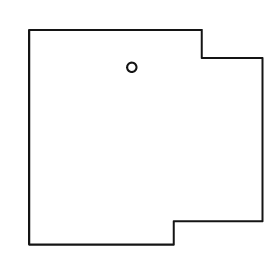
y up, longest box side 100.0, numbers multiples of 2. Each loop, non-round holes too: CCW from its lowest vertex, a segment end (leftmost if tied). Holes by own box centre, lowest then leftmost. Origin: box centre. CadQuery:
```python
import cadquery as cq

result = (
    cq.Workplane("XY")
    .moveTo(-50.0, -46.0)
    .lineTo(12.0, -46.0)
    .lineTo(12.0, -36.0)
    .lineTo(50.0, -36.0)
    .lineTo(50.0, 34.0)
    .lineTo(24.0, 34.0)
    .lineTo(24.0, 46.0)
    .lineTo(-50.0, 46.0)
    .close()
    .moveTo(-6.0, 30.0)
    .circle(2.0)
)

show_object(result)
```